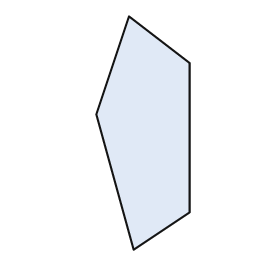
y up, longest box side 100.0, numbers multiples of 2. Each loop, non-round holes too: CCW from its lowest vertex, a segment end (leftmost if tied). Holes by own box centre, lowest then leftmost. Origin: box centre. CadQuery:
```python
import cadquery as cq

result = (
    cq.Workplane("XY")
    .moveTo(-4.0, -50.0)
    .lineTo(20.0, -34.0)
    .lineTo(20.0, 30.0)
    .lineTo(-6.0, 50.0)
    .lineTo(-20.0, 8.0)
    .close()
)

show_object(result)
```